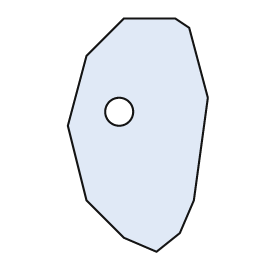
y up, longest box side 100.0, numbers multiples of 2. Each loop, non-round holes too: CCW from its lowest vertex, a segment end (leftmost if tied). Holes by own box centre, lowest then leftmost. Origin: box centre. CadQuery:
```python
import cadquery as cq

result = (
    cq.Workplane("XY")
    .moveTo(8.0, -50.0)
    .lineTo(18.0, -42.0)
    .lineTo(24.0, -28.0)
    .lineTo(30.0, 16.0)
    .lineTo(22.0, 46.0)
    .lineTo(16.0, 50.0)
    .lineTo(-6.0, 50.0)
    .lineTo(-22.0, 34.0)
    .lineTo(-30.0, 4.0)
    .lineTo(-22.0, -28.0)
    .lineTo(-6.0, -44.0)
    .close()
    .moveTo(-8.0, 10.0)
    .circle(6.0)
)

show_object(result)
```